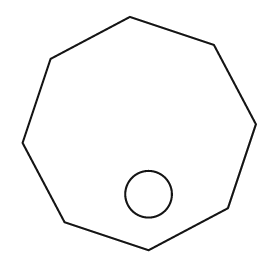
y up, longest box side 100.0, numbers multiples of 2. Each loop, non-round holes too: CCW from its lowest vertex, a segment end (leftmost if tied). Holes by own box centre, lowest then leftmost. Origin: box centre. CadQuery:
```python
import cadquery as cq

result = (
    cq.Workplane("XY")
    .moveTo(4.0, -50.0)
    .lineTo(38.0, -32.0)
    .lineTo(50.0, 4.0)
    .lineTo(32.0, 38.0)
    .lineTo(-4.0, 50.0)
    .lineTo(-38.0, 32.0)
    .lineTo(-50.0, -4.0)
    .lineTo(-32.0, -38.0)
    .close()
    .moveTo(4.0, -26.0)
    .circle(10.0)
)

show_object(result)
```